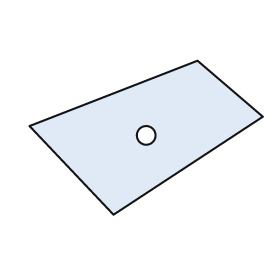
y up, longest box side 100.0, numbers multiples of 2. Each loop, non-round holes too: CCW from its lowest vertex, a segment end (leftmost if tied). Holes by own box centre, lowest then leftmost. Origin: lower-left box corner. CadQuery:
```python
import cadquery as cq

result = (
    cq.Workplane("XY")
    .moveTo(36.0, 0.0)
    .lineTo(100.0, 42.0)
    .lineTo(72.0, 66.0)
    .lineTo(0.0, 38.0)
    .close()
    .moveTo(50.0, 34.0)
    .circle(4.0)
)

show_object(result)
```